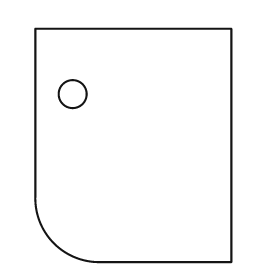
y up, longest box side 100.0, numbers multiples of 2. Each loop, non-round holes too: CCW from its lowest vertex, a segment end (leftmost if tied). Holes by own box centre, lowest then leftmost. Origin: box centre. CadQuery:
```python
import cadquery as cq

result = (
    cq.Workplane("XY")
    .moveTo(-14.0, -50.0)
    .lineTo(42.0, -50.0)
    .lineTo(42.0, 50.0)
    .lineTo(-42.0, 50.0)
    .lineTo(-42.0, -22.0)
    .threePointArc((-34.0, -42.0), (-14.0, -50.0))
    .close()
    .moveTo(-26.0, 22.0)
    .circle(6.0)
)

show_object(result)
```